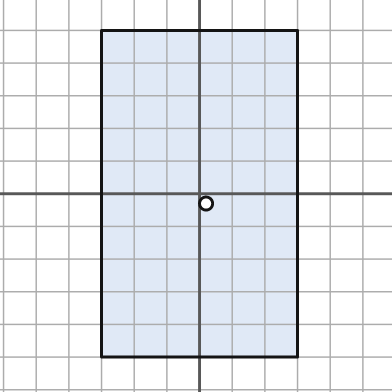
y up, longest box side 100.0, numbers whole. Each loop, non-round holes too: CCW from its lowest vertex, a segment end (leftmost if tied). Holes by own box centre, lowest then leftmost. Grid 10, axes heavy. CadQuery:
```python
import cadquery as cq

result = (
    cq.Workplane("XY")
    .moveTo(-30.0, -50.0)
    .lineTo(30.0, -50.0)
    .lineTo(30.0, 50.0)
    .lineTo(-30.0, 50.0)
    .close()
    .moveTo(2.0, -3.0)
    .circle(2.0)
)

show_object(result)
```